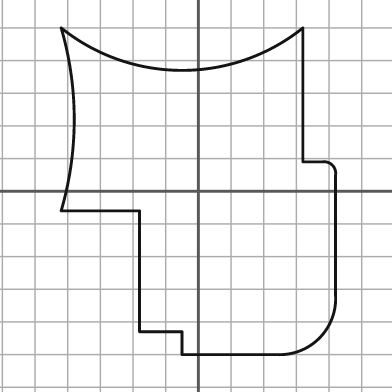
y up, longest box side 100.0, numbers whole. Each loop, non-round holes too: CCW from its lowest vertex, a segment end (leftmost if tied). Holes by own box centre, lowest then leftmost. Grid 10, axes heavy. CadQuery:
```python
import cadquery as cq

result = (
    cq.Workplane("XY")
    .moveTo(-5.0, -50.0)
    .lineTo(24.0, -50.0)
    .threePointArc((37.0, -45.0), (42.0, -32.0))
    .lineTo(42.0, 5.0)
    .threePointArc((41.0, 8.0), (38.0, 9.0))
    .lineTo(32.0, 9.0)
    .lineTo(32.0, 50.0)
    .threePointArc((-5.0, 37.0), (-42.0, 50.0))
    .threePointArc((-38.0, 22.0), (-42.0, -6.0))
    .lineTo(-18.0, -6.0)
    .lineTo(-18.0, -43.0)
    .lineTo(-5.0, -43.0)
    .close()
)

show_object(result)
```